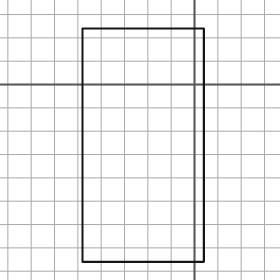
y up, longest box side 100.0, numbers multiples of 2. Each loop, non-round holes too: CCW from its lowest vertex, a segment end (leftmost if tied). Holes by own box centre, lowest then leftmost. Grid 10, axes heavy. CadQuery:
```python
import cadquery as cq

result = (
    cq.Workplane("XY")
    .moveTo(-48.0, -76.0)
    .lineTo(4.0, -76.0)
    .lineTo(4.0, 24.0)
    .lineTo(-48.0, 24.0)
    .close()
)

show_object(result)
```